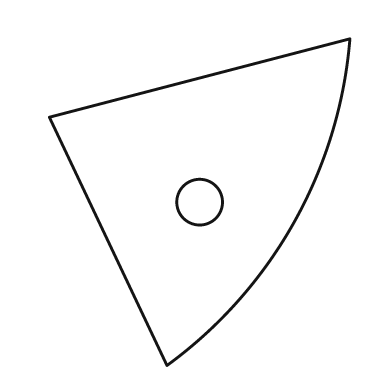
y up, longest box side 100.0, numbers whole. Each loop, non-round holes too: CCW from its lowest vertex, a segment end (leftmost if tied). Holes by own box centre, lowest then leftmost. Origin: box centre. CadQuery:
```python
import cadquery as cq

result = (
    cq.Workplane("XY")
    .moveTo(-10.0, -50.0)
    .threePointArc((29.0, -6.0), (46.0, 50.0))
    .lineTo(-46.0, 26.0)
    .close()
    .moveTo(0.0, 0.0)
    .circle(7.0)
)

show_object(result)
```